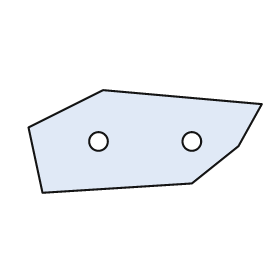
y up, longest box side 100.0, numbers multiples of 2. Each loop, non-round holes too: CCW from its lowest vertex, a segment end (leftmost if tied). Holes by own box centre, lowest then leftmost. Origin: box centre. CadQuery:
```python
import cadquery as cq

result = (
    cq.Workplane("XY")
    .moveTo(-44.0, -22.0)
    .lineTo(20.0, -18.0)
    .lineTo(40.0, -2.0)
    .lineTo(50.0, 16.0)
    .lineTo(-18.0, 22.0)
    .lineTo(-50.0, 6.0)
    .close()
    .moveTo(-20.0, 0.0)
    .circle(4.0)
    .moveTo(20.0, 0.0)
    .circle(4.0)
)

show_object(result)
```